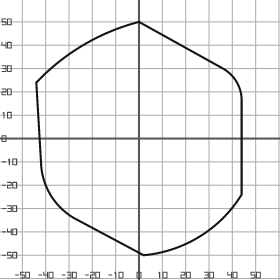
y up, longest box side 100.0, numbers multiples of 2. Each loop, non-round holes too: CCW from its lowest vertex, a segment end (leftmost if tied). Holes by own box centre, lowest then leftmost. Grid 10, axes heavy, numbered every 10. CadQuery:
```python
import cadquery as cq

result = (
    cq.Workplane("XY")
    .moveTo(2.0, -50.0)
    .threePointArc((26.0, -42.0), (44.0, -24.0))
    .lineTo(44.0, 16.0)
    .threePointArc((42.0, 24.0), (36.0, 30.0))
    .lineTo(0.0, 50.0)
    .threePointArc((-24.0, 40.0), (-44.0, 24.0))
    .lineTo(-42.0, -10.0)
    .threePointArc((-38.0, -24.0), (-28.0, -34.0))
    .close()
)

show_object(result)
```